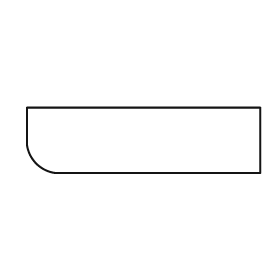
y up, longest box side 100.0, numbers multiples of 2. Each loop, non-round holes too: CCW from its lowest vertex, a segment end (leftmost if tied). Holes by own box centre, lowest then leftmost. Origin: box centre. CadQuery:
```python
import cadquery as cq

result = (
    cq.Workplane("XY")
    .moveTo(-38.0, -14.0)
    .lineTo(50.0, -14.0)
    .lineTo(50.0, 14.0)
    .lineTo(-50.0, 14.0)
    .lineTo(-50.0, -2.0)
    .threePointArc((-46.0, -10.0), (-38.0, -14.0))
    .close()
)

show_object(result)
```